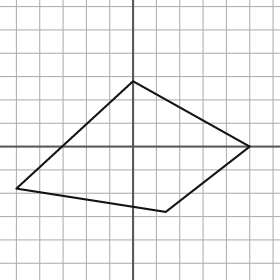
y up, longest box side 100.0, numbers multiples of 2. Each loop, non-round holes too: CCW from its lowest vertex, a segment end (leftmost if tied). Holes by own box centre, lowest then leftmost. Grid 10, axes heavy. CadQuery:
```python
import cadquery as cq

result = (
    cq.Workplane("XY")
    .moveTo(14.0, -28.0)
    .lineTo(50.0, 0.0)
    .lineTo(0.0, 28.0)
    .lineTo(-50.0, -18.0)
    .close()
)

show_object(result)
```